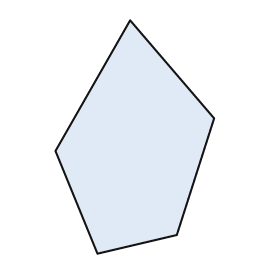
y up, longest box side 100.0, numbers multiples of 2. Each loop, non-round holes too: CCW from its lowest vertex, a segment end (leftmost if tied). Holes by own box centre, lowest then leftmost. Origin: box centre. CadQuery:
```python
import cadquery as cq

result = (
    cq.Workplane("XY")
    .moveTo(-16.0, -50.0)
    .lineTo(18.0, -42.0)
    .lineTo(34.0, 8.0)
    .lineTo(-2.0, 50.0)
    .lineTo(-34.0, -6.0)
    .close()
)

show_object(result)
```